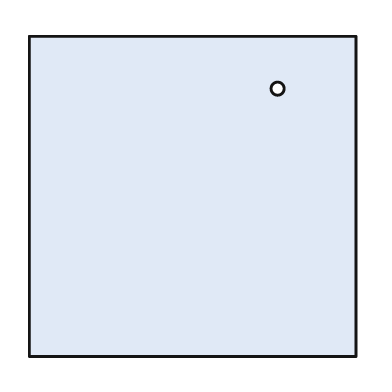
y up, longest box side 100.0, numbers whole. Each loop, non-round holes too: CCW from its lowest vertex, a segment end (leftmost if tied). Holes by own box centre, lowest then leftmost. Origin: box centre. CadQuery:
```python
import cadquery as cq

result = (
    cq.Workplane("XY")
    .moveTo(-50.0, -49.0)
    .lineTo(50.0, -49.0)
    .lineTo(50.0, 49.0)
    .lineTo(-50.0, 49.0)
    .close()
    .moveTo(26.0, 33.0)
    .circle(2.0)
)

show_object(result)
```